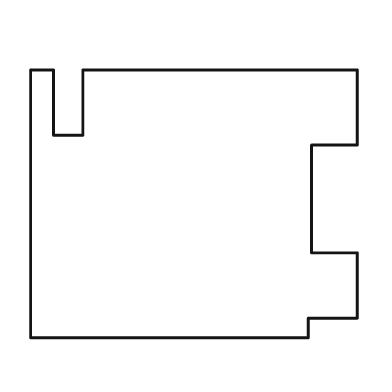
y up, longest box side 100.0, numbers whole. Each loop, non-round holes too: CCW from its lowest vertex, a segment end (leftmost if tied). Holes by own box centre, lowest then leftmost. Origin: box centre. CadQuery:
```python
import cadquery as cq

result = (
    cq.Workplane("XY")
    .moveTo(-50.0, -41.0)
    .lineTo(35.0, -41.0)
    .lineTo(35.0, -35.0)
    .lineTo(50.0, -35.0)
    .lineTo(50.0, -15.0)
    .lineTo(36.0, -15.0)
    .lineTo(36.0, 18.0)
    .lineTo(50.0, 18.0)
    .lineTo(50.0, 41.0)
    .lineTo(-34.0, 41.0)
    .lineTo(-34.0, 21.0)
    .lineTo(-43.0, 21.0)
    .lineTo(-43.0, 41.0)
    .lineTo(-50.0, 41.0)
    .close()
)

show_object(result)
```